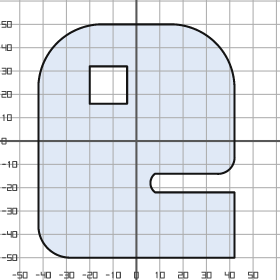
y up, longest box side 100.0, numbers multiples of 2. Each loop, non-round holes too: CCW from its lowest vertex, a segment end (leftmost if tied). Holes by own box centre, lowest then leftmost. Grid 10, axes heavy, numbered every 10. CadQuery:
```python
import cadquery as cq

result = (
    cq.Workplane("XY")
    .moveTo(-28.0, -50.0)
    .lineTo(42.0, -50.0)
    .lineTo(42.0, -22.0)
    .lineTo(8.0, -22.0)
    .threePointArc((6.0, -18.0), (8.0, -14.0))
    .lineTo(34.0, -14.0)
    .threePointArc((40.0, -12.0), (42.0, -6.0))
    .lineTo(42.0, 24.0)
    .threePointArc((34.0, 42.0), (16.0, 50.0))
    .lineTo(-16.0, 50.0)
    .threePointArc((-34.0, 42.0), (-42.0, 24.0))
    .lineTo(-42.0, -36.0)
    .threePointArc((-38.0, -46.0), (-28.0, -50.0))
    .close()
    .moveTo(-20.0, 16.0)
    .lineTo(-4.0, 16.0)
    .lineTo(-4.0, 32.0)
    .lineTo(-20.0, 32.0)
    .close()
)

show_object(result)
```